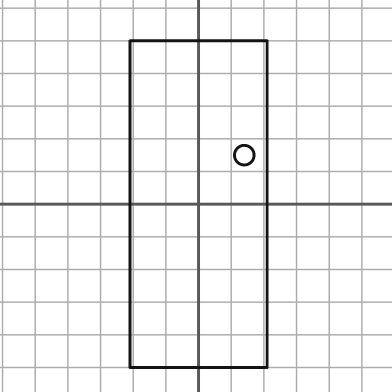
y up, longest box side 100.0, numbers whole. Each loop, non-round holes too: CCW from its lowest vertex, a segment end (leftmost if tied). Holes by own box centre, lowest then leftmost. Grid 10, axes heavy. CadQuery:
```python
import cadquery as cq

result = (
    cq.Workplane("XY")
    .moveTo(-21.0, -50.0)
    .lineTo(21.0, -50.0)
    .lineTo(21.0, 50.0)
    .lineTo(-21.0, 50.0)
    .close()
    .moveTo(14.0, 15.0)
    .circle(3.0)
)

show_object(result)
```